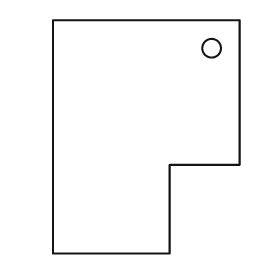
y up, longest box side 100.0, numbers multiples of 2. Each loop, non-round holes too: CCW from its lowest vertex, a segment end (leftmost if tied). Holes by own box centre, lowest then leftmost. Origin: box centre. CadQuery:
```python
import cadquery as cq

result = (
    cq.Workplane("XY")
    .moveTo(-40.0, -50.0)
    .lineTo(10.0, -50.0)
    .lineTo(10.0, -12.0)
    .lineTo(40.0, -12.0)
    .lineTo(40.0, 50.0)
    .lineTo(-40.0, 50.0)
    .close()
    .moveTo(28.0, 38.0)
    .circle(4.0)
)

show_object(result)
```